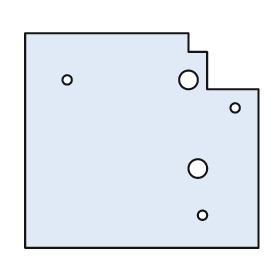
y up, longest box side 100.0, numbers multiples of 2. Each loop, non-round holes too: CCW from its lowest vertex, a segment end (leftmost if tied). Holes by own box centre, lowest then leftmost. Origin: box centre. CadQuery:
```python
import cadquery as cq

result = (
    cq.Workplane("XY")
    .moveTo(-50.0, -46.0)
    .lineTo(50.0, -46.0)
    .lineTo(50.0, 22.0)
    .lineTo(28.0, 22.0)
    .lineTo(28.0, 38.0)
    .lineTo(20.0, 38.0)
    .lineTo(20.0, 46.0)
    .lineTo(-50.0, 46.0)
    .close()
    .moveTo(26.0, -32.0)
    .circle(2.0)
    .moveTo(24.0, -12.0)
    .circle(4.0)
    .moveTo(40.0, 14.0)
    .circle(2.0)
    .moveTo(-32.0, 26.0)
    .circle(2.0)
    .moveTo(20.0, 26.0)
    .circle(4.0)
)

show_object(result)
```